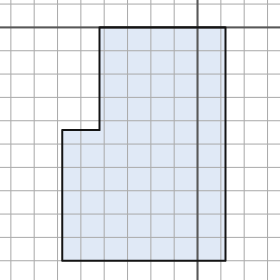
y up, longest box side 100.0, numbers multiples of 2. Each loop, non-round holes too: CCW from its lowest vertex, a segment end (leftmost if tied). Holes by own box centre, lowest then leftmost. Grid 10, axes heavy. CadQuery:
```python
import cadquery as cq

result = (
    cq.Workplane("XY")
    .moveTo(-58.0, -100.0)
    .lineTo(12.0, -100.0)
    .lineTo(12.0, 0.0)
    .lineTo(-42.0, 0.0)
    .lineTo(-42.0, -44.0)
    .lineTo(-58.0, -44.0)
    .close()
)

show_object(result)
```